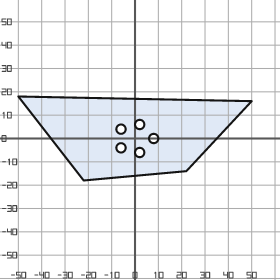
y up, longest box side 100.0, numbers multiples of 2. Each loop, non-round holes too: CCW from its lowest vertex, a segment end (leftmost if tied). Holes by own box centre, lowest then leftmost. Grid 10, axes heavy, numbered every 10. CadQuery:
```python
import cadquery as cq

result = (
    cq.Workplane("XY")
    .moveTo(-22.0, -18.0)
    .lineTo(22.0, -14.0)
    .lineTo(50.0, 16.0)
    .lineTo(-50.0, 18.0)
    .close()
    .moveTo(2.0, -6.0)
    .circle(2.0)
    .moveTo(-6.0, -4.0)
    .circle(2.0)
    .moveTo(8.0, 0.0)
    .circle(2.0)
    .moveTo(-6.0, 4.0)
    .circle(2.0)
    .moveTo(2.0, 6.0)
    .circle(2.0)
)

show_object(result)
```